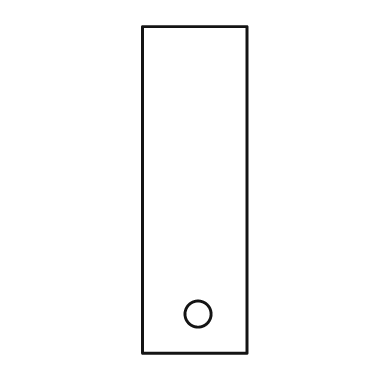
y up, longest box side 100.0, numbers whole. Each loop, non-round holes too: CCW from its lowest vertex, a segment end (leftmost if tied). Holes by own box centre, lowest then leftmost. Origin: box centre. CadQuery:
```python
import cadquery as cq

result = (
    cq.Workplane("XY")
    .moveTo(-16.0, -50.0)
    .lineTo(16.0, -50.0)
    .lineTo(16.0, 50.0)
    .lineTo(-16.0, 50.0)
    .close()
    .moveTo(1.0, -38.0)
    .circle(4.0)
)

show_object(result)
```